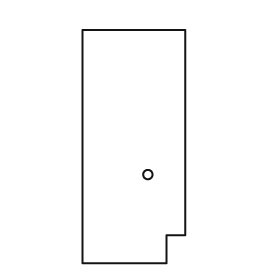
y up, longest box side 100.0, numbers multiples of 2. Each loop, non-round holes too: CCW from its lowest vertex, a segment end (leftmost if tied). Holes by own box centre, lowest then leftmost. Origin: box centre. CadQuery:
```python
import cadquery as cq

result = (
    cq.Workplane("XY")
    .moveTo(-22.0, -50.0)
    .lineTo(14.0, -50.0)
    .lineTo(14.0, -38.0)
    .lineTo(22.0, -38.0)
    .lineTo(22.0, 50.0)
    .lineTo(-22.0, 50.0)
    .close()
    .moveTo(6.0, -12.0)
    .circle(2.0)
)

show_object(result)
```